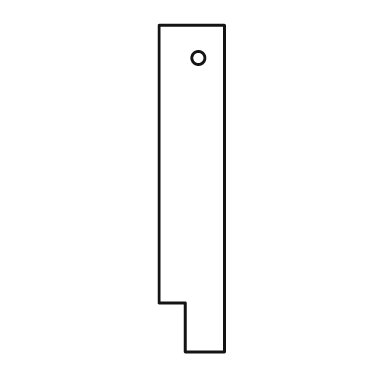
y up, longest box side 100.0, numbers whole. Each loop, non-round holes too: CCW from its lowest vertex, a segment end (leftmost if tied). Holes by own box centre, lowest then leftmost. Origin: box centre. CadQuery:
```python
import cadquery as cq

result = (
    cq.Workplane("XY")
    .moveTo(-2.0, -50.0)
    .lineTo(10.0, -50.0)
    .lineTo(10.0, 50.0)
    .lineTo(-10.0, 50.0)
    .lineTo(-10.0, -35.0)
    .lineTo(-2.0, -35.0)
    .close()
    .moveTo(2.0, 40.0)
    .circle(2.0)
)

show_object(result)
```